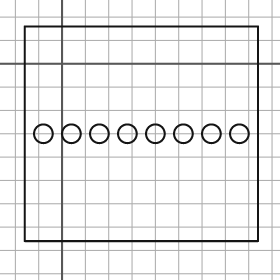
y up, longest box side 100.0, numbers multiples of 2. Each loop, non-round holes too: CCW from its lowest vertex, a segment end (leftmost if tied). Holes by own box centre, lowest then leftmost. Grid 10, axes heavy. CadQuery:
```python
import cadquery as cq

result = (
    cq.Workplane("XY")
    .moveTo(-16.0, -76.0)
    .lineTo(84.0, -76.0)
    .lineTo(84.0, 16.0)
    .lineTo(-16.0, 16.0)
    .close()
    .moveTo(-8.0, -30.0)
    .circle(4.0)
    .moveTo(4.0, -30.0)
    .circle(4.0)
    .moveTo(16.0, -30.0)
    .circle(4.0)
    .moveTo(28.0, -30.0)
    .circle(4.0)
    .moveTo(40.0, -30.0)
    .circle(4.0)
    .moveTo(52.0, -30.0)
    .circle(4.0)
    .moveTo(64.0, -30.0)
    .circle(4.0)
    .moveTo(76.0, -30.0)
    .circle(4.0)
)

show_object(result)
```